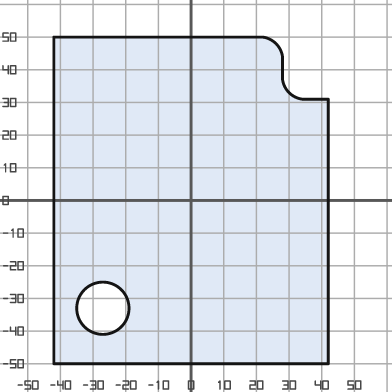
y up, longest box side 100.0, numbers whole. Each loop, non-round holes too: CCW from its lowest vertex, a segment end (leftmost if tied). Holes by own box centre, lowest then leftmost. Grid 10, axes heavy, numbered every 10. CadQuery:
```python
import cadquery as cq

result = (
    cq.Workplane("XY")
    .moveTo(-42.0, -50.0)
    .lineTo(42.0, -50.0)
    .lineTo(42.0, 31.0)
    .lineTo(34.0, 31.0)
    .threePointArc((30.0, 33.0), (28.0, 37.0))
    .lineTo(28.0, 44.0)
    .threePointArc((26.0, 48.0), (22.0, 50.0))
    .lineTo(-42.0, 50.0)
    .close()
    .moveTo(-27.0, -33.0)
    .circle(8.0)
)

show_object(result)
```